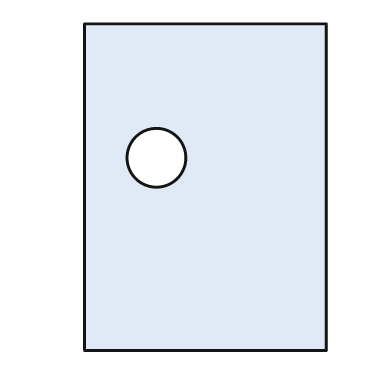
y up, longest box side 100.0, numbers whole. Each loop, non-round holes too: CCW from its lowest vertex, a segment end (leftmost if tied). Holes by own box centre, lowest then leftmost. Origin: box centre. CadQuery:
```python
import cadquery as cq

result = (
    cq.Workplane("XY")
    .moveTo(-37.0, -50.0)
    .lineTo(37.0, -50.0)
    .lineTo(37.0, 50.0)
    .lineTo(-37.0, 50.0)
    .close()
    .moveTo(-15.0, 9.0)
    .circle(9.0)
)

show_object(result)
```